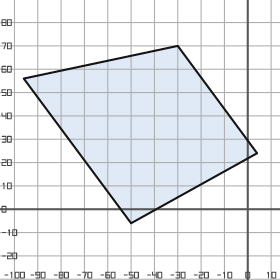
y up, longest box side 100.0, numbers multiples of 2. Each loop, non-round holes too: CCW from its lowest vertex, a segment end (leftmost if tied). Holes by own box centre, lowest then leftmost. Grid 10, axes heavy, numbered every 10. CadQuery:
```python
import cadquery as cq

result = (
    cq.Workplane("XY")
    .moveTo(-50.0, -6.0)
    .lineTo(4.0, 24.0)
    .lineTo(-30.0, 70.0)
    .lineTo(-96.0, 56.0)
    .close()
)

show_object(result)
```